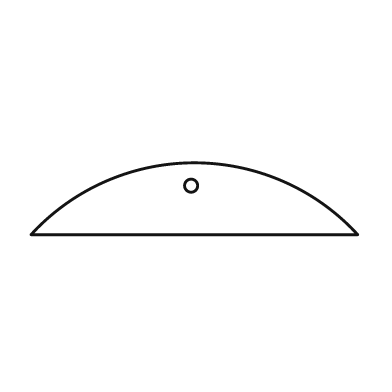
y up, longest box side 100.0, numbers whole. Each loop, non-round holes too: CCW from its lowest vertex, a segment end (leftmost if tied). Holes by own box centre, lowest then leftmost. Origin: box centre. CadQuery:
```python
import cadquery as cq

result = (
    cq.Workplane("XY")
    .moveTo(-50.0, -11.0)
    .lineTo(50.0, -11.0)
    .threePointArc((0.0, 11.0), (-50.0, -11.0))
    .close()
    .moveTo(-1.0, 4.0)
    .circle(2.0)
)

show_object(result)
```